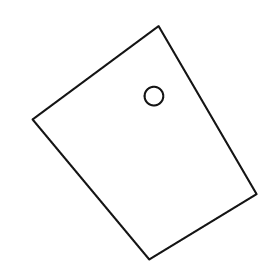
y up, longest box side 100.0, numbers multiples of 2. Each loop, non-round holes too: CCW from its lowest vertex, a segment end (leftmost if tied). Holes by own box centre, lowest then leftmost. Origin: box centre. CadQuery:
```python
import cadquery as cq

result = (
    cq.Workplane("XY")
    .moveTo(2.0, -50.0)
    .lineTo(48.0, -22.0)
    .lineTo(6.0, 50.0)
    .lineTo(-48.0, 10.0)
    .close()
    .moveTo(4.0, 20.0)
    .circle(4.0)
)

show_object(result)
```